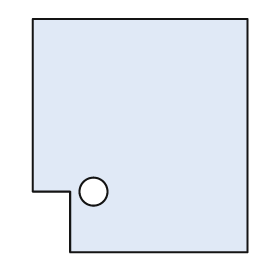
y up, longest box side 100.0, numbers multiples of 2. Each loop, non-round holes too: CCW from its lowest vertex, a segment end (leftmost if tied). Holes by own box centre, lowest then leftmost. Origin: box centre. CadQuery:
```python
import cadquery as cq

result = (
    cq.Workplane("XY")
    .moveTo(-30.0, -50.0)
    .lineTo(46.0, -50.0)
    .lineTo(46.0, 50.0)
    .lineTo(-46.0, 50.0)
    .lineTo(-46.0, -24.0)
    .lineTo(-30.0, -24.0)
    .close()
    .moveTo(-20.0, -24.0)
    .circle(6.0)
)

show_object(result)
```